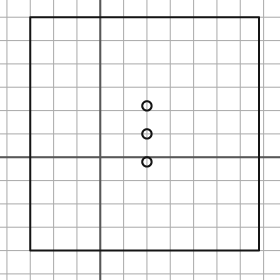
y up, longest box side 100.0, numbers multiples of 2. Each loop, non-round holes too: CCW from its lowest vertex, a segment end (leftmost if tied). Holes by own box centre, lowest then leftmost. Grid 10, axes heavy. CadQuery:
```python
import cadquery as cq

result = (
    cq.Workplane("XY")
    .moveTo(-30.0, -40.0)
    .lineTo(68.0, -40.0)
    .lineTo(68.0, 60.0)
    .lineTo(-30.0, 60.0)
    .close()
    .moveTo(20.0, -2.0)
    .circle(2.0)
    .moveTo(20.0, 10.0)
    .circle(2.0)
    .moveTo(20.0, 22.0)
    .circle(2.0)
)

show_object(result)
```